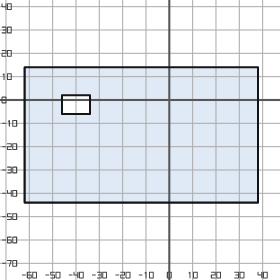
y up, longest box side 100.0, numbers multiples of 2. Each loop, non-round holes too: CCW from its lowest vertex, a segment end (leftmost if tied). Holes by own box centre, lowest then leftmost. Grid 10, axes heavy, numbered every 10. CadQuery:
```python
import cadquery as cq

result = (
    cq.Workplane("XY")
    .moveTo(-62.0, -44.0)
    .lineTo(38.0, -44.0)
    .lineTo(38.0, 14.0)
    .lineTo(-62.0, 14.0)
    .close()
    .moveTo(-46.0, -6.0)
    .lineTo(-34.0, -6.0)
    .lineTo(-34.0, 2.0)
    .lineTo(-46.0, 2.0)
    .close()
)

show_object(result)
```